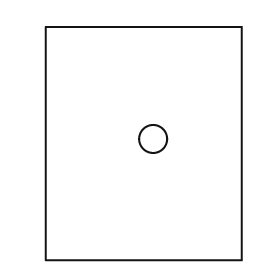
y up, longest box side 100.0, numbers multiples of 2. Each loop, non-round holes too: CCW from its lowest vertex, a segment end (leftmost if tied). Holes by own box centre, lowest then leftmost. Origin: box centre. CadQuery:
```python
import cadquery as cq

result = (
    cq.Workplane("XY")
    .moveTo(-42.0, -50.0)
    .lineTo(42.0, -50.0)
    .lineTo(42.0, 50.0)
    .lineTo(-42.0, 50.0)
    .close()
    .moveTo(4.0, 2.0)
    .circle(6.0)
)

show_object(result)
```